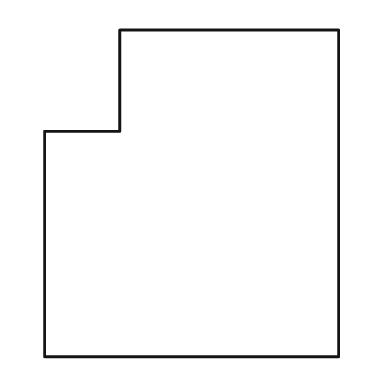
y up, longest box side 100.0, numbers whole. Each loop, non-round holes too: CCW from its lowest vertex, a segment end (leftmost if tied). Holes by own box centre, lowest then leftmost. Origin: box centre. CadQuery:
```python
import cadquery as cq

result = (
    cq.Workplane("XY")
    .moveTo(-45.0, -50.0)
    .lineTo(45.0, -50.0)
    .lineTo(45.0, 50.0)
    .lineTo(-22.0, 50.0)
    .lineTo(-22.0, 19.0)
    .lineTo(-45.0, 19.0)
    .close()
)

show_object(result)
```